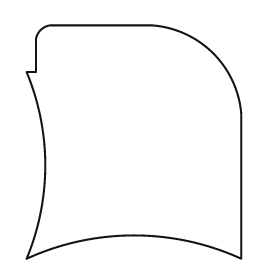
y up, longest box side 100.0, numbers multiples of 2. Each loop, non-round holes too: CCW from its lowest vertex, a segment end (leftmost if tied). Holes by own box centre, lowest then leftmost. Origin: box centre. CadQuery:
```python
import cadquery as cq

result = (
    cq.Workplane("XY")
    .moveTo(-46.0, -50.0)
    .threePointArc((0.0, -40.0), (46.0, -50.0))
    .lineTo(46.0, 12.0)
    .threePointArc((34.0, 38.0), (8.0, 50.0))
    .lineTo(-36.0, 50.0)
    .threePointArc((-40.0, 48.0), (-42.0, 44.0))
    .lineTo(-42.0, 30.0)
    .lineTo(-46.0, 30.0)
    .threePointArc((-38.0, -10.0), (-46.0, -50.0))
    .close()
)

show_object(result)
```